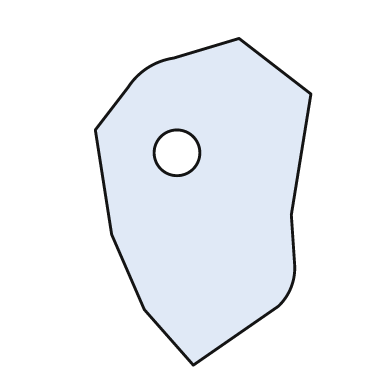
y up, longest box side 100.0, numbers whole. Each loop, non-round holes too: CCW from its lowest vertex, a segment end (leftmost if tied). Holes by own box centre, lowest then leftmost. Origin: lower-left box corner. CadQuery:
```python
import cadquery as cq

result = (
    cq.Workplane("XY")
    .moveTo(30.0, 0.0)
    .lineTo(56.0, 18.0)
    .threePointArc((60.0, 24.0), (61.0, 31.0))
    .lineTo(60.0, 46.0)
    .lineTo(66.0, 83.0)
    .lineTo(44.0, 100.0)
    .lineTo(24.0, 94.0)
    .threePointArc((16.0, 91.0), (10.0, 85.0))
    .lineTo(0.0, 72.0)
    .lineTo(5.0, 40.0)
    .lineTo(15.0, 17.0)
    .close()
    .moveTo(25.0, 65.0)
    .circle(7.0)
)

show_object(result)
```